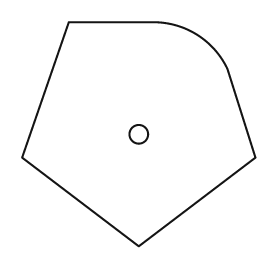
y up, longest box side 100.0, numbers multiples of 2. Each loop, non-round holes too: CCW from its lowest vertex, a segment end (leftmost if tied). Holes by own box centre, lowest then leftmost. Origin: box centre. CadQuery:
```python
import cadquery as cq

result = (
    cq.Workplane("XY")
    .moveTo(0.0, -48.0)
    .lineTo(50.0, -10.0)
    .lineTo(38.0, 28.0)
    .threePointArc((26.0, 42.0), (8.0, 48.0))
    .lineTo(-30.0, 48.0)
    .lineTo(-50.0, -10.0)
    .close()
    .moveTo(0.0, 0.0)
    .circle(4.0)
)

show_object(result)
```